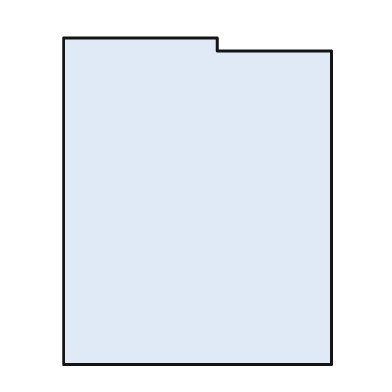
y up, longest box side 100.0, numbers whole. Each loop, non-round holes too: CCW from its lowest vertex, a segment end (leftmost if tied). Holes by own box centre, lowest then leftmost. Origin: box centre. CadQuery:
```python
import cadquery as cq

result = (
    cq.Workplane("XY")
    .moveTo(-41.0, -50.0)
    .lineTo(41.0, -50.0)
    .lineTo(41.0, 46.0)
    .lineTo(6.0, 46.0)
    .lineTo(6.0, 50.0)
    .lineTo(-41.0, 50.0)
    .close()
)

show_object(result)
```